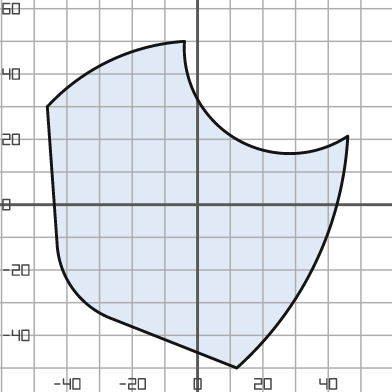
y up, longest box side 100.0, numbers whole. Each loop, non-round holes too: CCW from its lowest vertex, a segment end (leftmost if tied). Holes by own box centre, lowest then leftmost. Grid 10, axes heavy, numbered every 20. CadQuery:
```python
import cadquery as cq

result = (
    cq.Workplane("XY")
    .moveTo(12.0, -50.0)
    .threePointArc((36.0, -18.0), (46.0, 21.0))
    .threePointArc((12.0, 20.0), (-4.0, 50.0))
    .threePointArc((-27.0, 44.0), (-46.0, 30.0))
    .lineTo(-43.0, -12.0)
    .threePointArc((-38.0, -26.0), (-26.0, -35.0))
    .close()
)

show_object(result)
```